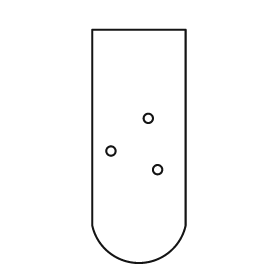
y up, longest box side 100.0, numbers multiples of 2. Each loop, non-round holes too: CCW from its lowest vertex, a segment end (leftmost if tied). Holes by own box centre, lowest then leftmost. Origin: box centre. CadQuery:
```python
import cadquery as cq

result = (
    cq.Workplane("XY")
    .moveTo(-20.0, -34.0)
    .threePointArc((0.0, -50.0), (20.0, -34.0))
    .lineTo(20.0, 50.0)
    .lineTo(-20.0, 50.0)
    .close()
    .moveTo(8.0, -10.0)
    .circle(2.0)
    .moveTo(-12.0, -2.0)
    .circle(2.0)
    .moveTo(4.0, 12.0)
    .circle(2.0)
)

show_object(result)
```